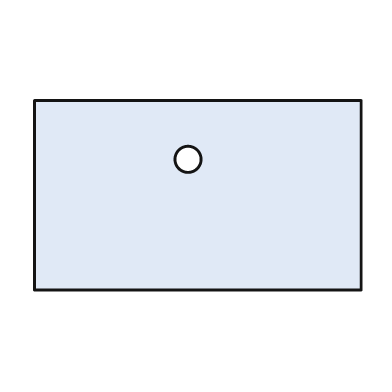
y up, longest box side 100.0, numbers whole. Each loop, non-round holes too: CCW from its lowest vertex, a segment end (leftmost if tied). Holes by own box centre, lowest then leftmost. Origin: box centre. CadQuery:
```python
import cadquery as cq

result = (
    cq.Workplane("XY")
    .moveTo(-50.0, -29.0)
    .lineTo(50.0, -29.0)
    .lineTo(50.0, 29.0)
    .lineTo(-50.0, 29.0)
    .close()
    .moveTo(-3.0, 11.0)
    .circle(4.0)
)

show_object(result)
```